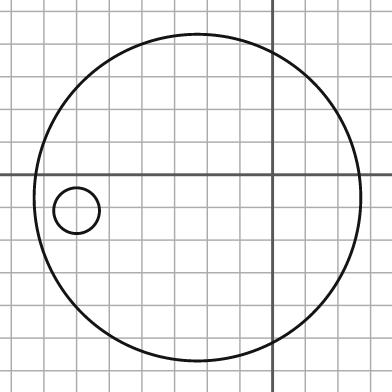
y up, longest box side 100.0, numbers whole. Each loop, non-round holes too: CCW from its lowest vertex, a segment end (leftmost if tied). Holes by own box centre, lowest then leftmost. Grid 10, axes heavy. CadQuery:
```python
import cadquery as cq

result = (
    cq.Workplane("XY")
    .moveTo(-23.0, -7.0)
    .circle(50.0)
    .moveTo(-60.0, -11.0)
    .circle(7.0)
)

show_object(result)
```